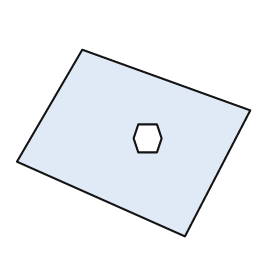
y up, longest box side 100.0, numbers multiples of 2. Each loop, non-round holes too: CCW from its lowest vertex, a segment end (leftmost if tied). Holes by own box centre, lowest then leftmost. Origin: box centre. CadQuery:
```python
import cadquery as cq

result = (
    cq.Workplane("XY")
    .moveTo(22.0, -40.0)
    .lineTo(50.0, 14.0)
    .lineTo(-22.0, 40.0)
    .lineTo(-50.0, -8.0)
    .close()
    .moveTo(2.0, -4.0)
    .lineTo(10.0, -4.0)
    .lineTo(12.0, 2.0)
    .lineTo(10.0, 8.0)
    .lineTo(2.0, 8.0)
    .lineTo(0.0, 2.0)
    .close()
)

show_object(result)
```